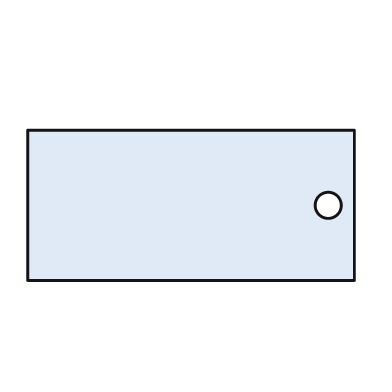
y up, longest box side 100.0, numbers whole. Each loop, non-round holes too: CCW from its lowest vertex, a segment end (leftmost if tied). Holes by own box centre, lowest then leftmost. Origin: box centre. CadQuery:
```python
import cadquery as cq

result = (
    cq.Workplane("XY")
    .moveTo(-50.0, -23.0)
    .lineTo(50.0, -23.0)
    .lineTo(50.0, 23.0)
    .lineTo(-50.0, 23.0)
    .close()
    .moveTo(42.0, 0.0)
    .circle(4.0)
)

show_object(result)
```